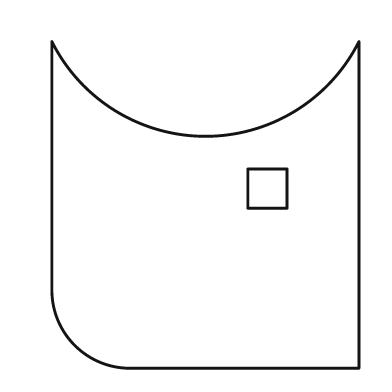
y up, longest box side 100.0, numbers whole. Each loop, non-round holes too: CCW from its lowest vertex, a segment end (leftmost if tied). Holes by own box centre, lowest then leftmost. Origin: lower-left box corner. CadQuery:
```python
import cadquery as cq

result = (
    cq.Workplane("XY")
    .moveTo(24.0, 0.0)
    .lineTo(94.0, 0.0)
    .lineTo(94.0, 100.0)
    .threePointArc((47.0, 71.0), (0.0, 100.0))
    .lineTo(0.0, 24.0)
    .threePointArc((7.0, 7.0), (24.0, 0.0))
    .close()
    .moveTo(60.0, 49.0)
    .lineTo(72.0, 49.0)
    .lineTo(72.0, 61.0)
    .lineTo(60.0, 61.0)
    .close()
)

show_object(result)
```